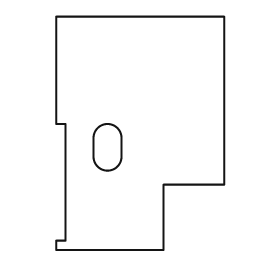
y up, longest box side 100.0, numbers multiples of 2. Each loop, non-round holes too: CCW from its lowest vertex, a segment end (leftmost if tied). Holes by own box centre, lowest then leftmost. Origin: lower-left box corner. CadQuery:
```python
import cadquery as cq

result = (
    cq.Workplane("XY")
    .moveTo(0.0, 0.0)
    .lineTo(46.0, 0.0)
    .lineTo(46.0, 28.0)
    .lineTo(72.0, 28.0)
    .lineTo(72.0, 100.0)
    .lineTo(0.0, 100.0)
    .lineTo(0.0, 54.0)
    .lineTo(4.0, 54.0)
    .lineTo(4.0, 4.0)
    .lineTo(0.0, 4.0)
    .close()
    .moveTo(16.0, 40.0)
    .threePointArc((22.0, 34.0), (28.0, 40.0))
    .lineTo(28.0, 48.0)
    .threePointArc((22.0, 54.0), (16.0, 48.0))
    .close()
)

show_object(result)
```